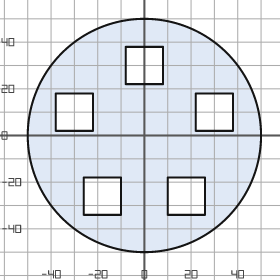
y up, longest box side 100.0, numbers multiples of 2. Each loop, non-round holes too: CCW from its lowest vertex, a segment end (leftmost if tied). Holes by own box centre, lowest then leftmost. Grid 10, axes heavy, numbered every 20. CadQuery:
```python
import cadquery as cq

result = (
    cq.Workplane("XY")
    .moveTo(0.0, 0.0)
    .circle(50.0)
    .moveTo(-26.0, -34.0)
    .lineTo(-10.0, -34.0)
    .lineTo(-10.0, -18.0)
    .lineTo(-26.0, -18.0)
    .close()
    .moveTo(10.0, -34.0)
    .lineTo(26.0, -34.0)
    .lineTo(26.0, -18.0)
    .lineTo(10.0, -18.0)
    .close()
    .moveTo(-38.0, 2.0)
    .lineTo(-22.0, 2.0)
    .lineTo(-22.0, 18.0)
    .lineTo(-38.0, 18.0)
    .close()
    .moveTo(22.0, 2.0)
    .lineTo(38.0, 2.0)
    .lineTo(38.0, 18.0)
    .lineTo(22.0, 18.0)
    .close()
    .moveTo(-8.0, 22.0)
    .lineTo(8.0, 22.0)
    .lineTo(8.0, 38.0)
    .lineTo(-8.0, 38.0)
    .close()
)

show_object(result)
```